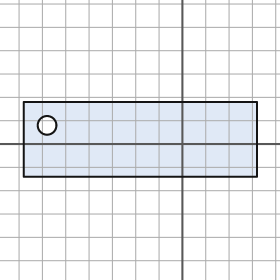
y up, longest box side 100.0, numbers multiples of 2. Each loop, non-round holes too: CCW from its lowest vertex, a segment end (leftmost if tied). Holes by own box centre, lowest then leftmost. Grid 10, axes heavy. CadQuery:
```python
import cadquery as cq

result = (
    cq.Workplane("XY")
    .moveTo(-68.0, -14.0)
    .lineTo(32.0, -14.0)
    .lineTo(32.0, 18.0)
    .lineTo(-68.0, 18.0)
    .close()
    .moveTo(-58.0, 8.0)
    .circle(4.0)
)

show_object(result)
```